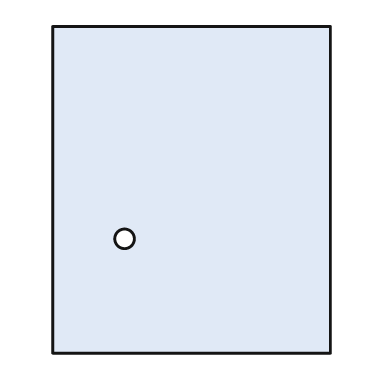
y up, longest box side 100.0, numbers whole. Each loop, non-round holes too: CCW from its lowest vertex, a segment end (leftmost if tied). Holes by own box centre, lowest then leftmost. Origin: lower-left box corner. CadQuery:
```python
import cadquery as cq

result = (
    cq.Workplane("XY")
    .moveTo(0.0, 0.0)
    .lineTo(85.0, 0.0)
    .lineTo(85.0, 100.0)
    .lineTo(0.0, 100.0)
    .close()
    .moveTo(22.0, 35.0)
    .circle(3.0)
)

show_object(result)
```